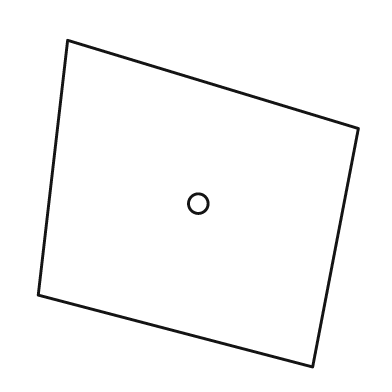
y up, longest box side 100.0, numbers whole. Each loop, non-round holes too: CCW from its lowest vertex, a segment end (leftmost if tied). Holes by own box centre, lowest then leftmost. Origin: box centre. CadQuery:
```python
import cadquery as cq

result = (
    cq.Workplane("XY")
    .moveTo(35.0, -50.0)
    .lineTo(49.0, 23.0)
    .lineTo(-40.0, 50.0)
    .lineTo(-49.0, -28.0)
    .close()
    .moveTo(0.0, 0.0)
    .circle(3.0)
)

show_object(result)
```